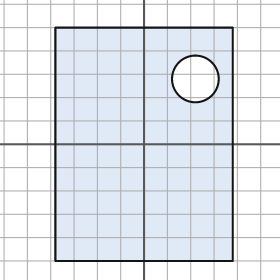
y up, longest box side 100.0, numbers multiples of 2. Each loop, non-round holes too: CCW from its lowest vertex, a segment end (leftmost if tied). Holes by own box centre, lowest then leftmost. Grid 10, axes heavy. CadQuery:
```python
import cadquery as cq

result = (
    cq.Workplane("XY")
    .moveTo(-38.0, -50.0)
    .lineTo(38.0, -50.0)
    .lineTo(38.0, 50.0)
    .lineTo(-38.0, 50.0)
    .close()
    .moveTo(22.0, 28.0)
    .circle(10.0)
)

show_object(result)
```